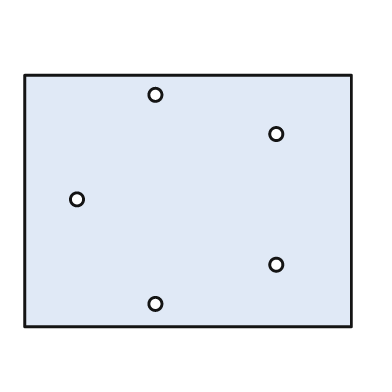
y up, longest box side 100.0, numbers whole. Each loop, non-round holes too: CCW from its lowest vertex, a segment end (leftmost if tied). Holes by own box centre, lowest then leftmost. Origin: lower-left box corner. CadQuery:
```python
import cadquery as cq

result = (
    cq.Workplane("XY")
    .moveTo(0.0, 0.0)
    .lineTo(100.0, 0.0)
    .lineTo(100.0, 77.0)
    .lineTo(0.0, 77.0)
    .close()
    .moveTo(40.0, 7.0)
    .circle(2.0)
    .moveTo(77.0, 19.0)
    .circle(2.0)
    .moveTo(16.0, 39.0)
    .circle(2.0)
    .moveTo(77.0, 59.0)
    .circle(2.0)
    .moveTo(40.0, 71.0)
    .circle(2.0)
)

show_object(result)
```